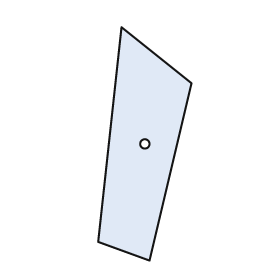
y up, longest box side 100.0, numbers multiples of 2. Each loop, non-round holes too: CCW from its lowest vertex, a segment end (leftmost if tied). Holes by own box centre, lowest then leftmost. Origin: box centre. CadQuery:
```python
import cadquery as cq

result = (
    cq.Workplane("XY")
    .moveTo(2.0, -50.0)
    .lineTo(20.0, 26.0)
    .lineTo(-10.0, 50.0)
    .lineTo(-20.0, -42.0)
    .close()
    .moveTo(0.0, 0.0)
    .circle(2.0)
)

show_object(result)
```